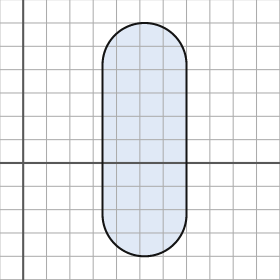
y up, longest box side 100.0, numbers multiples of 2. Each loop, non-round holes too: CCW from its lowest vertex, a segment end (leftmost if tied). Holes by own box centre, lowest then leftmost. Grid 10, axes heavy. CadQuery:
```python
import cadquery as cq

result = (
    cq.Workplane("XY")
    .moveTo(34.0, -22.0)
    .threePointArc((52.0, -40.0), (70.0, -22.0))
    .lineTo(70.0, 42.0)
    .threePointArc((52.0, 60.0), (34.0, 42.0))
    .close()
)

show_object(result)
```